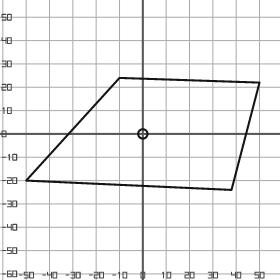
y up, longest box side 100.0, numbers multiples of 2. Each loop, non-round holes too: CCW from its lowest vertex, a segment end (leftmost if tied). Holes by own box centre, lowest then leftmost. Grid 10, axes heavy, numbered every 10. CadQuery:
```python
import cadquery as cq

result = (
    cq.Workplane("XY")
    .moveTo(38.0, -24.0)
    .lineTo(50.0, 22.0)
    .lineTo(-10.0, 24.0)
    .lineTo(-50.0, -20.0)
    .close()
    .moveTo(0.0, 0.0)
    .circle(2.0)
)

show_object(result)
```